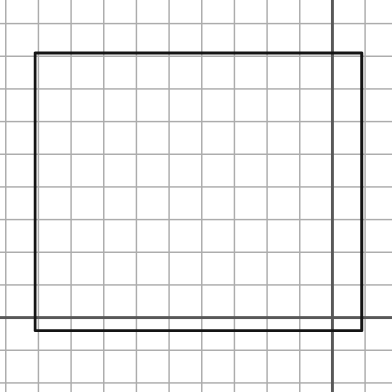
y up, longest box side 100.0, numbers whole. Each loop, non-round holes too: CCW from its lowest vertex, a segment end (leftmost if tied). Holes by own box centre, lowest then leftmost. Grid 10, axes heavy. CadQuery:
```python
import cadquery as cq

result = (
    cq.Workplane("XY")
    .moveTo(-91.0, -4.0)
    .lineTo(9.0, -4.0)
    .lineTo(9.0, 81.0)
    .lineTo(-91.0, 81.0)
    .close()
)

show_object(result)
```